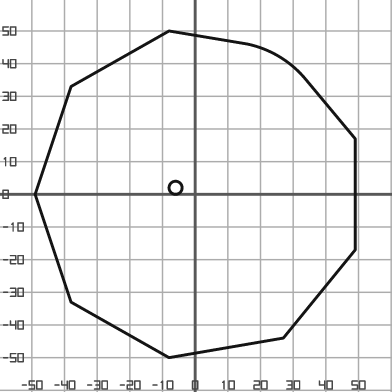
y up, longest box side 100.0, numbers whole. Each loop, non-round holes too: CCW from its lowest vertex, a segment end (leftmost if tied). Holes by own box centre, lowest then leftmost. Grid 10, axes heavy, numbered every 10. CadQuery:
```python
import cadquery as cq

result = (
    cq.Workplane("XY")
    .moveTo(-8.0, -50.0)
    .lineTo(27.0, -44.0)
    .lineTo(49.0, -17.0)
    .lineTo(49.0, 17.0)
    .lineTo(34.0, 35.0)
    .threePointArc((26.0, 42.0), (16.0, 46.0))
    .lineTo(-8.0, 50.0)
    .lineTo(-38.0, 33.0)
    .lineTo(-49.0, 0.0)
    .lineTo(-38.0, -33.0)
    .close()
    .moveTo(-6.0, 2.0)
    .circle(2.0)
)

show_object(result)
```